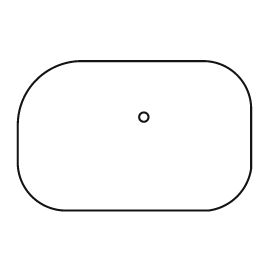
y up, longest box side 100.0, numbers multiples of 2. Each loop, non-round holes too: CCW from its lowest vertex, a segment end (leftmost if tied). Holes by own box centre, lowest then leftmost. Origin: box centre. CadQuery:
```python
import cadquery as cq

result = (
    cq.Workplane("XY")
    .moveTo(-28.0, -32.0)
    .lineTo(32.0, -32.0)
    .threePointArc((44.0, -26.0), (50.0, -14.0))
    .lineTo(50.0, 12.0)
    .threePointArc((44.0, 26.0), (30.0, 32.0))
    .lineTo(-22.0, 32.0)
    .threePointArc((-42.0, 24.0), (-50.0, 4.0))
    .lineTo(-50.0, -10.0)
    .threePointArc((-44.0, -26.0), (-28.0, -32.0))
    .close()
    .moveTo(4.0, 8.0)
    .circle(2.0)
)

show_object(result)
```